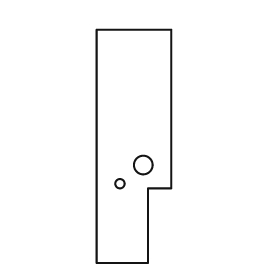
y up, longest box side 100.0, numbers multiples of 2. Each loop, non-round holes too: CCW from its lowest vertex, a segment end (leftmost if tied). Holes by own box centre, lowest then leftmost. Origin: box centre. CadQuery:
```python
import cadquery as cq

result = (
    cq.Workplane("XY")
    .moveTo(-16.0, -50.0)
    .lineTo(6.0, -50.0)
    .lineTo(6.0, -18.0)
    .lineTo(16.0, -18.0)
    .lineTo(16.0, 50.0)
    .lineTo(-16.0, 50.0)
    .close()
    .moveTo(-6.0, -16.0)
    .circle(2.0)
    .moveTo(4.0, -8.0)
    .circle(4.0)
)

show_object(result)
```